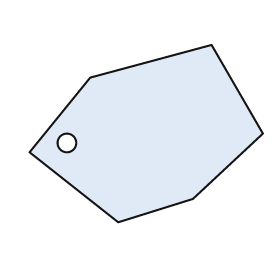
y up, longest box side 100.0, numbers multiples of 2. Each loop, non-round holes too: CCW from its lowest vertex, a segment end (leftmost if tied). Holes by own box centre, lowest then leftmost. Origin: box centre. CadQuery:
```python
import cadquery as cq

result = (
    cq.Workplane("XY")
    .moveTo(-12.0, -38.0)
    .lineTo(20.0, -28.0)
    .lineTo(50.0, 0.0)
    .lineTo(28.0, 38.0)
    .lineTo(-24.0, 24.0)
    .lineTo(-50.0, -8.0)
    .close()
    .moveTo(-34.0, -4.0)
    .circle(4.0)
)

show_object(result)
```